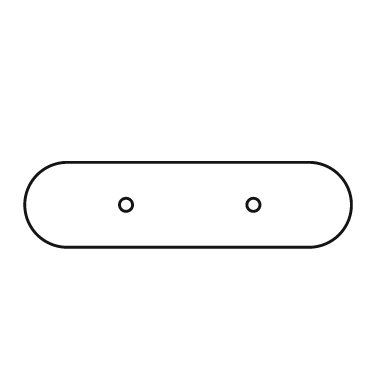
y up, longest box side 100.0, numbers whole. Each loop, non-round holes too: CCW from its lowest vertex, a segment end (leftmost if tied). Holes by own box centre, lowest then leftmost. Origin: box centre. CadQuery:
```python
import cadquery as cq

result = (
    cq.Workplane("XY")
    .moveTo(-37.0, -13.0)
    .lineTo(37.0, -13.0)
    .threePointArc((50.0, 0.0), (37.0, 13.0))
    .lineTo(-37.0, 13.0)
    .threePointArc((-50.0, 0.0), (-37.0, -13.0))
    .close()
    .moveTo(-19.0, 0.0)
    .circle(2.0)
    .moveTo(20.0, 0.0)
    .circle(2.0)
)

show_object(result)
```